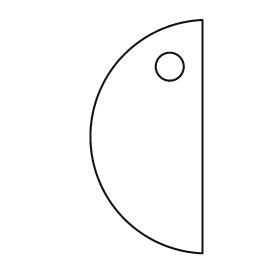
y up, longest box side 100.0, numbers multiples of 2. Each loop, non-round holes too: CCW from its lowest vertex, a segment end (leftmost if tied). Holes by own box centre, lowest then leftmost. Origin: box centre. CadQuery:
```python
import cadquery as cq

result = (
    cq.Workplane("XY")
    .moveTo(24.0, -50.0)
    .lineTo(24.0, 50.0)
    .threePointArc((-24.0, 0.0), (24.0, -50.0))
    .close()
    .moveTo(10.0, 30.0)
    .circle(6.0)
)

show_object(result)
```